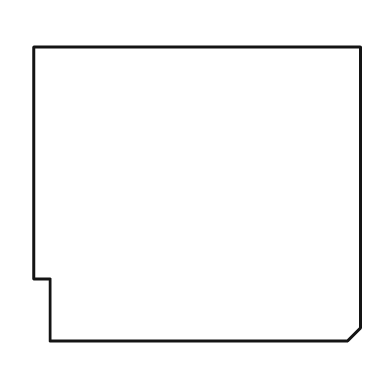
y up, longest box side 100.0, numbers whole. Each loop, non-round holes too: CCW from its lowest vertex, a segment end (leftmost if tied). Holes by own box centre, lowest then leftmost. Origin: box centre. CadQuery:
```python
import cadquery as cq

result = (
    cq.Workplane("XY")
    .moveTo(-45.0, -45.0)
    .lineTo(46.0, -45.0)
    .lineTo(50.0, -41.0)
    .lineTo(50.0, 45.0)
    .lineTo(-50.0, 45.0)
    .lineTo(-50.0, -26.0)
    .lineTo(-45.0, -26.0)
    .close()
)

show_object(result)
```